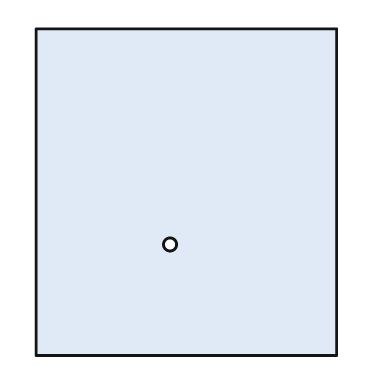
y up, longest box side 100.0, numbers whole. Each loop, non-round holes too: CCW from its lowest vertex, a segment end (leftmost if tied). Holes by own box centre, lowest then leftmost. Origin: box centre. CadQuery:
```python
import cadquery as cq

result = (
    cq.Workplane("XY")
    .moveTo(-46.0, -50.0)
    .lineTo(46.0, -50.0)
    .lineTo(46.0, 50.0)
    .lineTo(-46.0, 50.0)
    .close()
    .moveTo(-5.0, -16.0)
    .circle(2.0)
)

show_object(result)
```